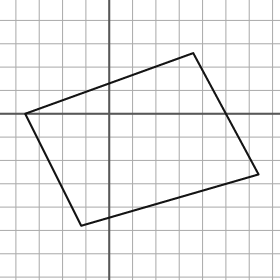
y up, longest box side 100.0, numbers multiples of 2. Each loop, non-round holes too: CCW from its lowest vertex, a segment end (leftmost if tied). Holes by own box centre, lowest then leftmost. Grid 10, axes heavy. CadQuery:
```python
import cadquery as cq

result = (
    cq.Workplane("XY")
    .moveTo(-12.0, -48.0)
    .lineTo(64.0, -26.0)
    .lineTo(36.0, 26.0)
    .lineTo(-36.0, 0.0)
    .close()
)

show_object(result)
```